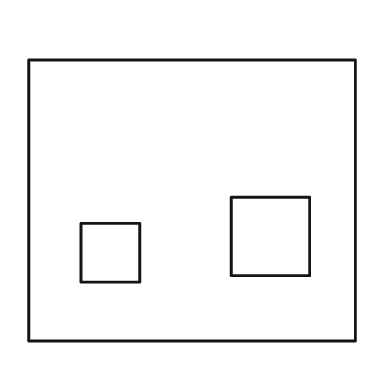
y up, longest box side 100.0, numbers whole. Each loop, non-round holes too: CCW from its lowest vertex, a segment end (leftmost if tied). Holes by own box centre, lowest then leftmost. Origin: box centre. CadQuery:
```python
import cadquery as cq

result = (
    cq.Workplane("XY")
    .moveTo(-50.0, -43.0)
    .lineTo(50.0, -43.0)
    .lineTo(50.0, 43.0)
    .lineTo(-50.0, 43.0)
    .close()
    .moveTo(-34.0, -25.0)
    .lineTo(-16.0, -25.0)
    .lineTo(-16.0, -7.0)
    .lineTo(-34.0, -7.0)
    .close()
    .moveTo(12.0, -23.0)
    .lineTo(36.0, -23.0)
    .lineTo(36.0, 1.0)
    .lineTo(12.0, 1.0)
    .close()
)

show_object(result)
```